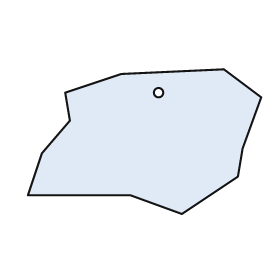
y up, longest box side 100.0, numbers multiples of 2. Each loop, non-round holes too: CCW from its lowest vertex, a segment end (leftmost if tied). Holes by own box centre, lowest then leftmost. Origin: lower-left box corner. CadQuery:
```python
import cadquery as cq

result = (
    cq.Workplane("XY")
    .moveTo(66.0, 0.0)
    .lineTo(90.0, 16.0)
    .lineTo(92.0, 28.0)
    .lineTo(100.0, 50.0)
    .lineTo(84.0, 62.0)
    .lineTo(40.0, 60.0)
    .lineTo(16.0, 52.0)
    .lineTo(18.0, 40.0)
    .lineTo(6.0, 26.0)
    .lineTo(0.0, 8.0)
    .lineTo(44.0, 8.0)
    .close()
    .moveTo(56.0, 52.0)
    .circle(2.0)
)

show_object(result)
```